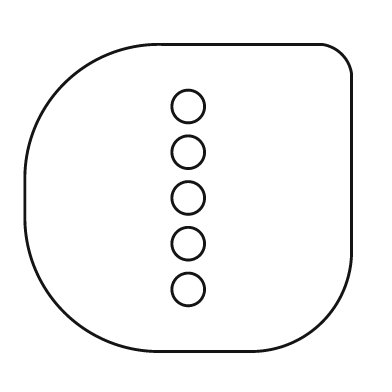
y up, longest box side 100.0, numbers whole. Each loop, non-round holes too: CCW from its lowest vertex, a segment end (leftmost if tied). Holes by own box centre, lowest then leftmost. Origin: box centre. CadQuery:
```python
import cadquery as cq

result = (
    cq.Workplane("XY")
    .moveTo(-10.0, -47.0)
    .lineTo(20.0, -47.0)
    .threePointArc((41.0, -38.0), (50.0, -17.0))
    .lineTo(50.0, 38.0)
    .threePointArc((47.0, 44.0), (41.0, 47.0))
    .lineTo(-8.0, 47.0)
    .threePointArc((-38.0, 35.0), (-50.0, 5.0))
    .lineTo(-50.0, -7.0)
    .threePointArc((-38.0, -35.0), (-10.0, -47.0))
    .close()
    .moveTo(0.0, -28.0)
    .circle(5.0)
    .moveTo(0.0, -14.0)
    .circle(5.0)
    .moveTo(0.0, 0.0)
    .circle(5.0)
    .moveTo(0.0, 14.0)
    .circle(5.0)
    .moveTo(0.0, 28.0)
    .circle(5.0)
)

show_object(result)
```